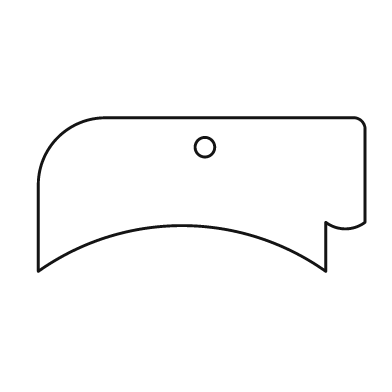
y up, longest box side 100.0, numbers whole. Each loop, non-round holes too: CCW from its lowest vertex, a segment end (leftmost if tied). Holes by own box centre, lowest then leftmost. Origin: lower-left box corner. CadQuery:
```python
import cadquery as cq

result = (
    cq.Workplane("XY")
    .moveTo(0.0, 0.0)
    .threePointArc((44.0, 14.0), (88.0, 0.0))
    .lineTo(88.0, 15.0)
    .threePointArc((94.0, 13.0), (100.0, 15.0))
    .lineTo(100.0, 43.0)
    .threePointArc((99.0, 46.0), (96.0, 47.0))
    .lineTo(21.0, 47.0)
    .threePointArc((6.0, 41.0), (0.0, 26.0))
    .close()
    .moveTo(51.0, 38.0)
    .circle(3.0)
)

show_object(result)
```